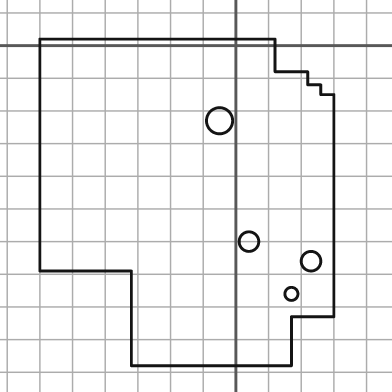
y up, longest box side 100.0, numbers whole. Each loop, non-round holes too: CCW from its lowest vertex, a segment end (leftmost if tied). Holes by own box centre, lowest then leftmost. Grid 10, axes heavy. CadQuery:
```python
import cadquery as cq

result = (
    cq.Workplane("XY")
    .moveTo(-32.0, -98.0)
    .lineTo(17.0, -98.0)
    .lineTo(17.0, -83.0)
    .lineTo(30.0, -83.0)
    .lineTo(30.0, -15.0)
    .lineTo(26.0, -15.0)
    .lineTo(26.0, -12.0)
    .lineTo(22.0, -12.0)
    .lineTo(22.0, -8.0)
    .lineTo(12.0, -8.0)
    .lineTo(12.0, 2.0)
    .lineTo(-60.0, 2.0)
    .lineTo(-60.0, -69.0)
    .lineTo(-32.0, -69.0)
    .close()
    .moveTo(17.0, -76.0)
    .circle(2.0)
    .moveTo(23.0, -66.0)
    .circle(3.0)
    .moveTo(4.0, -60.0)
    .circle(3.0)
    .moveTo(-5.0, -23.0)
    .circle(4.0)
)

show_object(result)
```